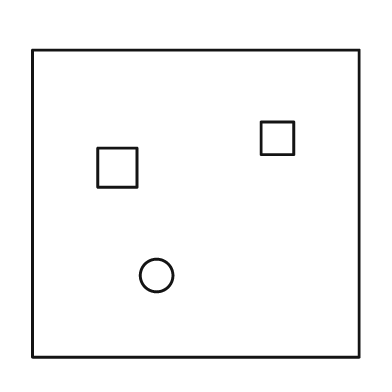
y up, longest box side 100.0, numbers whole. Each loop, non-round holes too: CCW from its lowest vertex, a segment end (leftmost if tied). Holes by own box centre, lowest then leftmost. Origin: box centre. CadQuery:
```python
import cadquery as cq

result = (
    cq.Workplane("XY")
    .moveTo(-50.0, -47.0)
    .lineTo(50.0, -47.0)
    .lineTo(50.0, 47.0)
    .lineTo(-50.0, 47.0)
    .close()
    .moveTo(-12.0, -22.0)
    .circle(5.0)
    .moveTo(-30.0, 5.0)
    .lineTo(-18.0, 5.0)
    .lineTo(-18.0, 17.0)
    .lineTo(-30.0, 17.0)
    .close()
    .moveTo(20.0, 15.0)
    .lineTo(30.0, 15.0)
    .lineTo(30.0, 25.0)
    .lineTo(20.0, 25.0)
    .close()
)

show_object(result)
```